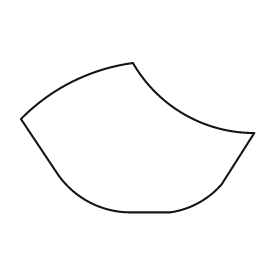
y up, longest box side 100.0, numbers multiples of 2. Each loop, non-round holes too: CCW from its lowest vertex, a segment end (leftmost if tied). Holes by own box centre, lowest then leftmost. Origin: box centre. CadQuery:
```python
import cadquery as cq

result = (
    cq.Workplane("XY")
    .moveTo(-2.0, -32.0)
    .lineTo(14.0, -32.0)
    .threePointArc((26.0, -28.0), (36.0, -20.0))
    .lineTo(50.0, 2.0)
    .threePointArc((20.0, 10.0), (-2.0, 32.0))
    .threePointArc((-28.0, 24.0), (-50.0, 8.0))
    .lineTo(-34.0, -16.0)
    .threePointArc((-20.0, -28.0), (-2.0, -32.0))
    .close()
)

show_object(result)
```